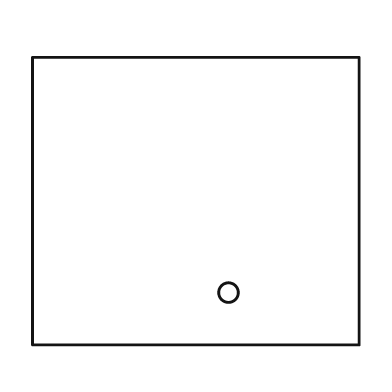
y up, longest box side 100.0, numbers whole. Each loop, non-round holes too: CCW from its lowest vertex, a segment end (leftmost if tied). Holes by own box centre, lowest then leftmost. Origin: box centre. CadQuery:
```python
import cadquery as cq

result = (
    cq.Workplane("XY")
    .moveTo(-50.0, -44.0)
    .lineTo(50.0, -44.0)
    .lineTo(50.0, 44.0)
    .lineTo(-50.0, 44.0)
    .close()
    .moveTo(10.0, -28.0)
    .circle(3.0)
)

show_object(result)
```